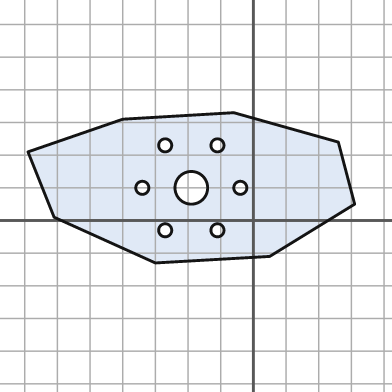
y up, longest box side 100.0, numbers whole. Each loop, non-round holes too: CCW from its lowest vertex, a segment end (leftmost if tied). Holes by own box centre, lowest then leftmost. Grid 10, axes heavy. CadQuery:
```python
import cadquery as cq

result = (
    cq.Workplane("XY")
    .moveTo(-30.0, -13.0)
    .lineTo(5.0, -11.0)
    .lineTo(31.0, 5.0)
    .lineTo(26.0, 24.0)
    .lineTo(-6.0, 33.0)
    .lineTo(-40.0, 31.0)
    .lineTo(-69.0, 21.0)
    .lineTo(-61.0, 1.0)
    .close()
    .moveTo(-27.0, -3.0)
    .circle(2.0)
    .moveTo(-11.0, -3.0)
    .circle(2.0)
    .moveTo(-34.0, 10.0)
    .circle(2.0)
    .moveTo(-19.0, 10.0)
    .circle(5.0)
    .moveTo(-4.0, 10.0)
    .circle(2.0)
    .moveTo(-27.0, 23.0)
    .circle(2.0)
    .moveTo(-11.0, 23.0)
    .circle(2.0)
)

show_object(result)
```